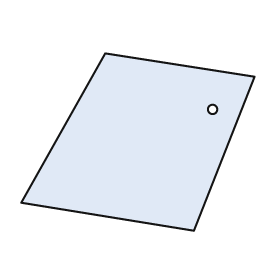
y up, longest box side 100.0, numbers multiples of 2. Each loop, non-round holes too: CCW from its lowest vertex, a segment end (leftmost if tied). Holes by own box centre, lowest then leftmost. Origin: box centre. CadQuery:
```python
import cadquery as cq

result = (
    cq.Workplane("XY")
    .moveTo(24.0, -38.0)
    .lineTo(50.0, 28.0)
    .lineTo(-14.0, 38.0)
    .lineTo(-50.0, -26.0)
    .close()
    .moveTo(32.0, 14.0)
    .circle(2.0)
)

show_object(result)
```